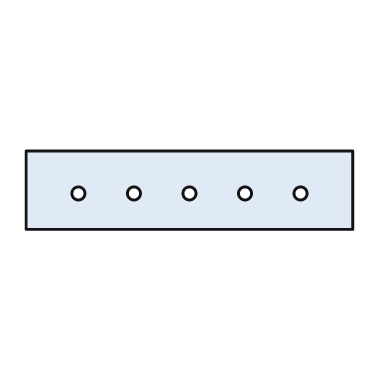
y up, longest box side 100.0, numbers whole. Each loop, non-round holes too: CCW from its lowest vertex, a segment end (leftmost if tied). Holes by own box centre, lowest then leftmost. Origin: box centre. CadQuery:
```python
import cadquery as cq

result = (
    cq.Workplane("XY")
    .moveTo(-50.0, -12.0)
    .lineTo(50.0, -12.0)
    .lineTo(50.0, 12.0)
    .lineTo(-50.0, 12.0)
    .close()
    .moveTo(-34.0, -1.0)
    .circle(2.0)
    .moveTo(-17.0, -1.0)
    .circle(2.0)
    .moveTo(0.0, -1.0)
    .circle(2.0)
    .moveTo(17.0, -1.0)
    .circle(2.0)
    .moveTo(34.0, -1.0)
    .circle(2.0)
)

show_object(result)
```